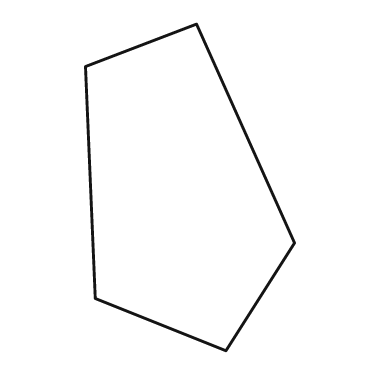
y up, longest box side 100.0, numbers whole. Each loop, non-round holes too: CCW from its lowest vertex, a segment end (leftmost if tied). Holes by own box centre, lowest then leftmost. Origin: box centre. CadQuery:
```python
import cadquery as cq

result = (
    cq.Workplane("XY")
    .moveTo(11.0, -50.0)
    .lineTo(32.0, -17.0)
    .lineTo(2.0, 50.0)
    .lineTo(-32.0, 37.0)
    .lineTo(-29.0, -34.0)
    .close()
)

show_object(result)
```